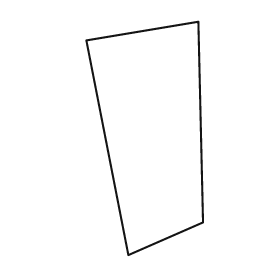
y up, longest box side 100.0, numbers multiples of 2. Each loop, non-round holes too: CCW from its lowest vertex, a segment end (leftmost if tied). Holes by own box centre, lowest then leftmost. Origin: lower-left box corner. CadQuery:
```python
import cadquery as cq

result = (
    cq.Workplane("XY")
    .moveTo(18.0, 0.0)
    .lineTo(50.0, 14.0)
    .lineTo(48.0, 100.0)
    .lineTo(0.0, 92.0)
    .close()
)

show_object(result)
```